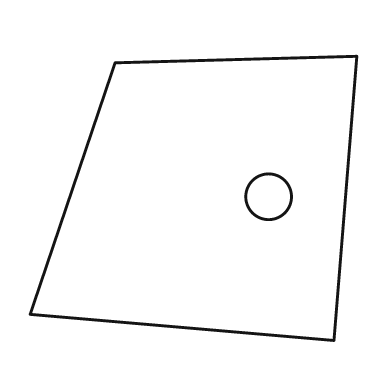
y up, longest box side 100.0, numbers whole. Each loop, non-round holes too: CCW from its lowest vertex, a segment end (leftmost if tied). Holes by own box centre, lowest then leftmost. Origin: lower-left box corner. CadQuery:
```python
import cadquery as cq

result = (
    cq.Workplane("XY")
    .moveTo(93.0, 0.0)
    .lineTo(100.0, 87.0)
    .lineTo(26.0, 85.0)
    .lineTo(0.0, 8.0)
    .close()
    .moveTo(73.0, 44.0)
    .circle(7.0)
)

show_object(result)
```